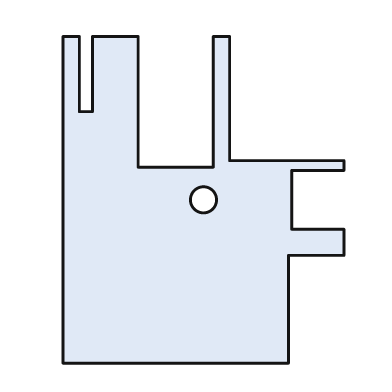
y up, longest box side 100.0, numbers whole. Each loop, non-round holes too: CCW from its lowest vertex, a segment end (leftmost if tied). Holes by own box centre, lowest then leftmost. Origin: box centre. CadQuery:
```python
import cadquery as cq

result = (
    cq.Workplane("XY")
    .moveTo(-43.0, -50.0)
    .lineTo(26.0, -50.0)
    .lineTo(26.0, -17.0)
    .lineTo(43.0, -17.0)
    .lineTo(43.0, -9.0)
    .lineTo(27.0, -9.0)
    .lineTo(27.0, 9.0)
    .lineTo(43.0, 9.0)
    .lineTo(43.0, 12.0)
    .lineTo(8.0, 12.0)
    .lineTo(8.0, 50.0)
    .lineTo(3.0, 50.0)
    .lineTo(3.0, 10.0)
    .lineTo(-20.0, 10.0)
    .lineTo(-20.0, 50.0)
    .lineTo(-34.0, 50.0)
    .lineTo(-34.0, 27.0)
    .lineTo(-38.0, 27.0)
    .lineTo(-38.0, 50.0)
    .lineTo(-43.0, 50.0)
    .close()
    .moveTo(0.0, 0.0)
    .circle(4.0)
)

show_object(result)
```